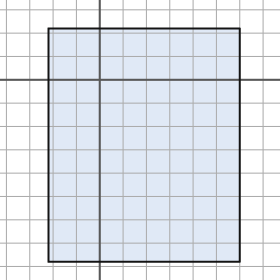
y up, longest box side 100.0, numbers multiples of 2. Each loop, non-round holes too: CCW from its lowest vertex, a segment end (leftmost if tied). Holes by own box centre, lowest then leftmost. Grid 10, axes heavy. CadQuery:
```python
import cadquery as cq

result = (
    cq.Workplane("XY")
    .moveTo(-22.0, -78.0)
    .lineTo(60.0, -78.0)
    .lineTo(60.0, 22.0)
    .lineTo(-22.0, 22.0)
    .close()
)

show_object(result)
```